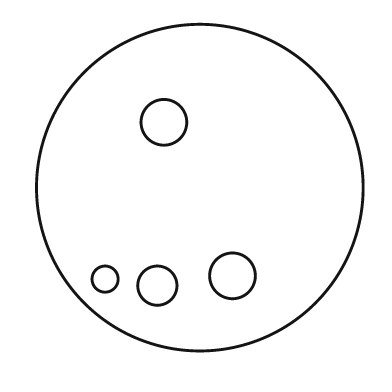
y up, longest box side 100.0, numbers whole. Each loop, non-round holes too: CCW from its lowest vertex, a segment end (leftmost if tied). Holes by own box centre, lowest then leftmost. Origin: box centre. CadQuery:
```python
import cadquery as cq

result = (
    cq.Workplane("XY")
    .moveTo(0.0, 0.0)
    .circle(50.0)
    .moveTo(-13.0, -30.0)
    .circle(6.0)
    .moveTo(-29.0, -28.0)
    .circle(4.0)
    .moveTo(10.0, -27.0)
    .circle(7.0)
    .moveTo(-11.0, 20.0)
    .circle(7.0)
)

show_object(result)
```